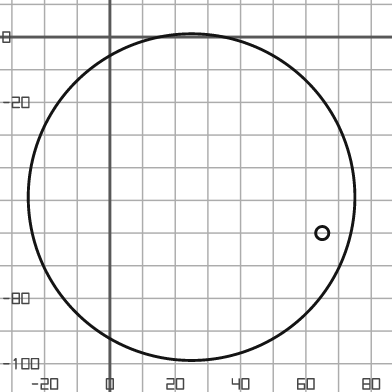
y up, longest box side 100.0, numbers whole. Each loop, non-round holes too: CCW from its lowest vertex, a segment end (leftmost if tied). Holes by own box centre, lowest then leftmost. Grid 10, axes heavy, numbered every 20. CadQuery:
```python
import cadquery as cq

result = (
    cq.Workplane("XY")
    .moveTo(25.0, -49.0)
    .circle(50.0)
    .moveTo(65.0, -60.0)
    .circle(2.0)
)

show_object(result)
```